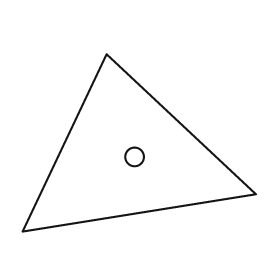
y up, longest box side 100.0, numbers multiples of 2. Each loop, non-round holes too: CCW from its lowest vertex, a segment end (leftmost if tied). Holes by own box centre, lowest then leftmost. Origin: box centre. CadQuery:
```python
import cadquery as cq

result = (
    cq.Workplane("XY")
    .moveTo(-50.0, -38.0)
    .lineTo(50.0, -22.0)
    .lineTo(-14.0, 38.0)
    .close()
    .moveTo(-2.0, -6.0)
    .circle(4.0)
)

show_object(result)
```